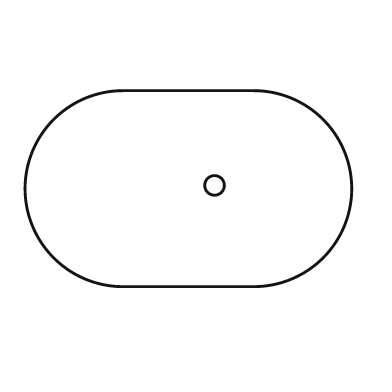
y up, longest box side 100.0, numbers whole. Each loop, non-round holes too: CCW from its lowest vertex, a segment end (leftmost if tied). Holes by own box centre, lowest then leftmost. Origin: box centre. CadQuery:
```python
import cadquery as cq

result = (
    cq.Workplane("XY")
    .moveTo(-20.0, -30.0)
    .lineTo(20.0, -30.0)
    .threePointArc((50.0, 0.0), (20.0, 30.0))
    .lineTo(-20.0, 30.0)
    .threePointArc((-50.0, 0.0), (-20.0, -30.0))
    .close()
    .moveTo(8.0, 1.0)
    .circle(3.0)
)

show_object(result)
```